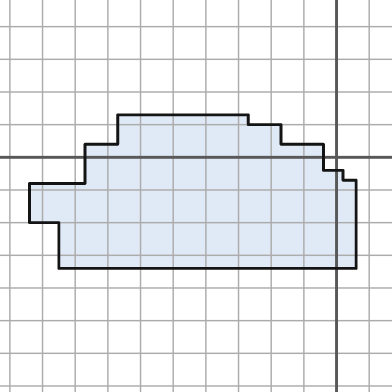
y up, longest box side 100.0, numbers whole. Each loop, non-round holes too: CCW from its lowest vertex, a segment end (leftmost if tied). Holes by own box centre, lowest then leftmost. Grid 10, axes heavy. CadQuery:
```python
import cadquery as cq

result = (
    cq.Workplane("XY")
    .moveTo(-85.0, -34.0)
    .lineTo(6.0, -34.0)
    .lineTo(6.0, -7.0)
    .lineTo(2.0, -7.0)
    .lineTo(2.0, -4.0)
    .lineTo(-4.0, -4.0)
    .lineTo(-4.0, 4.0)
    .lineTo(-17.0, 4.0)
    .lineTo(-17.0, 10.0)
    .lineTo(-27.0, 10.0)
    .lineTo(-27.0, 13.0)
    .lineTo(-67.0, 13.0)
    .lineTo(-67.0, 4.0)
    .lineTo(-77.0, 4.0)
    .lineTo(-77.0, -8.0)
    .lineTo(-94.0, -8.0)
    .lineTo(-94.0, -20.0)
    .lineTo(-85.0, -20.0)
    .close()
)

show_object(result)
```